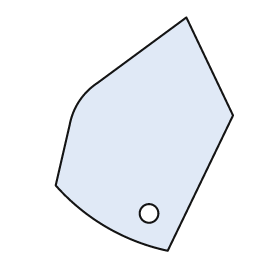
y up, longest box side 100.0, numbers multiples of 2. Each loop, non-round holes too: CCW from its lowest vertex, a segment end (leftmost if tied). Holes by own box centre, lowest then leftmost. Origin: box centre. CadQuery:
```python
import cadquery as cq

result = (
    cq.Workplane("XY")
    .moveTo(10.0, -50.0)
    .lineTo(38.0, 8.0)
    .lineTo(18.0, 50.0)
    .lineTo(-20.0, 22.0)
    .threePointArc((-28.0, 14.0), (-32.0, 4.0))
    .lineTo(-38.0, -22.0)
    .threePointArc((-16.0, -40.0), (10.0, -50.0))
    .close()
    .moveTo(2.0, -34.0)
    .circle(4.0)
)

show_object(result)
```